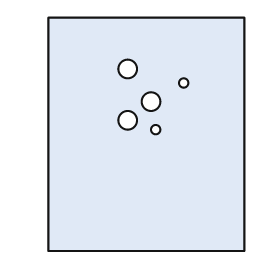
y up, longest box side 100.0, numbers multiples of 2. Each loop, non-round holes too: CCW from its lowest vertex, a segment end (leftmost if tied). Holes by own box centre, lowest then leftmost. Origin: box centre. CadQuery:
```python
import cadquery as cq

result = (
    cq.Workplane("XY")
    .moveTo(-42.0, -50.0)
    .lineTo(42.0, -50.0)
    .lineTo(42.0, 50.0)
    .lineTo(-42.0, 50.0)
    .close()
    .moveTo(4.0, 2.0)
    .circle(2.0)
    .moveTo(-8.0, 6.0)
    .circle(4.0)
    .moveTo(2.0, 14.0)
    .circle(4.0)
    .moveTo(16.0, 22.0)
    .circle(2.0)
    .moveTo(-8.0, 28.0)
    .circle(4.0)
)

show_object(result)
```